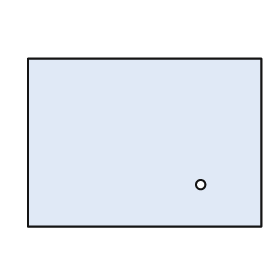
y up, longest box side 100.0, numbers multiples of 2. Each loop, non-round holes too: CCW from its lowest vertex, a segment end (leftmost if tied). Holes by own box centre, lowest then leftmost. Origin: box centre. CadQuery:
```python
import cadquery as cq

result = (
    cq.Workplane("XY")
    .moveTo(-50.0, -36.0)
    .lineTo(50.0, -36.0)
    .lineTo(50.0, 36.0)
    .lineTo(-50.0, 36.0)
    .close()
    .moveTo(24.0, -18.0)
    .circle(2.0)
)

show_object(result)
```